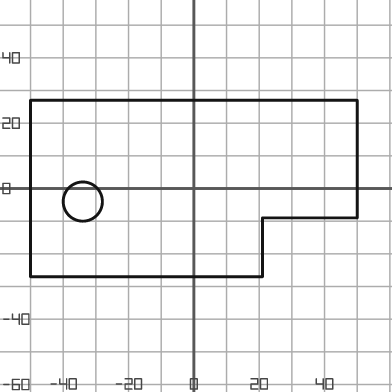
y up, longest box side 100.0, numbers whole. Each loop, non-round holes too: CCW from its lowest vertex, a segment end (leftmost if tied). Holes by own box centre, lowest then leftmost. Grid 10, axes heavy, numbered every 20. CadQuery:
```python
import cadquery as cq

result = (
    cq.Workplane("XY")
    .moveTo(-50.0, -27.0)
    .lineTo(21.0, -27.0)
    .lineTo(21.0, -9.0)
    .lineTo(50.0, -9.0)
    .lineTo(50.0, 27.0)
    .lineTo(-50.0, 27.0)
    .close()
    .moveTo(-34.0, -4.0)
    .circle(6.0)
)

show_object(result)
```